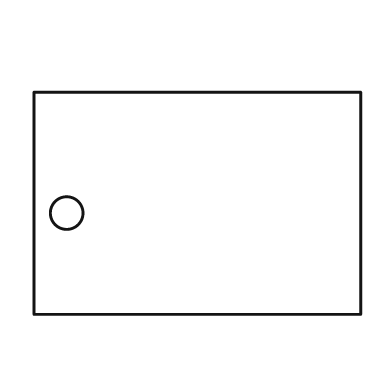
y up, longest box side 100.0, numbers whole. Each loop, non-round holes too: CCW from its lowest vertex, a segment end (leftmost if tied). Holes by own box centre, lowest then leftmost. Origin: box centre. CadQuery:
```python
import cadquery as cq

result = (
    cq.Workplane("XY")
    .moveTo(-50.0, -34.0)
    .lineTo(50.0, -34.0)
    .lineTo(50.0, 34.0)
    .lineTo(-50.0, 34.0)
    .close()
    .moveTo(-40.0, -3.0)
    .circle(5.0)
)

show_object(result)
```